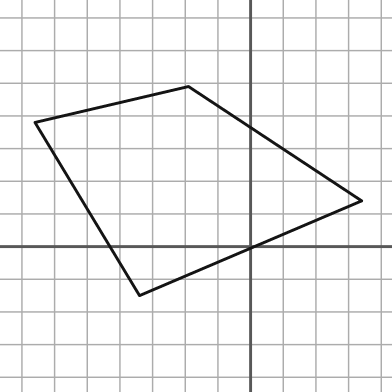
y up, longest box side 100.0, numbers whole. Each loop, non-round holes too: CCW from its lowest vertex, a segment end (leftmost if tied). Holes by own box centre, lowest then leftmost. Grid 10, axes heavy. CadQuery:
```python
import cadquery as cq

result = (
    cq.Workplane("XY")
    .moveTo(-34.0, -15.0)
    .lineTo(34.0, 14.0)
    .lineTo(-19.0, 49.0)
    .lineTo(-66.0, 38.0)
    .close()
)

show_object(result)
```